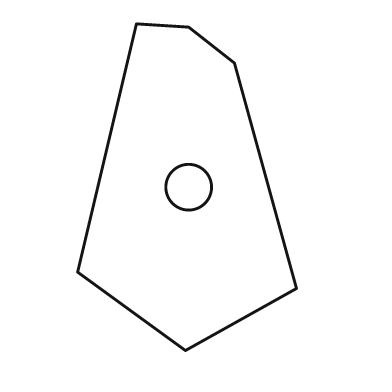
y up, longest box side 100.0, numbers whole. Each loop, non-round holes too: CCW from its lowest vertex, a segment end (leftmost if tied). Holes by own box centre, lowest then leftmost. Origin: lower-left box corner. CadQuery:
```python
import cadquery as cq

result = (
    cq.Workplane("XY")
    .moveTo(33.0, 0.0)
    .lineTo(67.0, 19.0)
    .lineTo(48.0, 88.0)
    .lineTo(34.0, 99.0)
    .lineTo(18.0, 100.0)
    .lineTo(0.0, 24.0)
    .close()
    .moveTo(34.0, 50.0)
    .circle(7.0)
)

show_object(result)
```